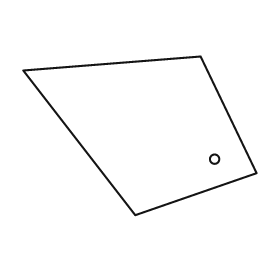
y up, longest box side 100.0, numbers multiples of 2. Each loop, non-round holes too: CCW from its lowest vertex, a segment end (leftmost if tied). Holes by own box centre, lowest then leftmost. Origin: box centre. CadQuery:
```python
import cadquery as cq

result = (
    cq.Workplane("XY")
    .moveTo(-2.0, -34.0)
    .lineTo(50.0, -16.0)
    .lineTo(26.0, 34.0)
    .lineTo(-50.0, 28.0)
    .close()
    .moveTo(32.0, -10.0)
    .circle(2.0)
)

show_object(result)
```